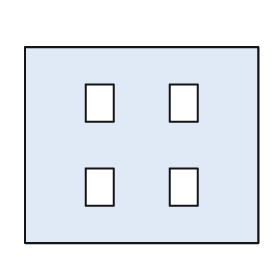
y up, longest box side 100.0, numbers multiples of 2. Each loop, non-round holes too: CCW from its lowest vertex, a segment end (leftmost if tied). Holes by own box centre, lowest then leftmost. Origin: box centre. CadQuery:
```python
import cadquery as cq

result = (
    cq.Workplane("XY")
    .moveTo(-50.0, -42.0)
    .lineTo(50.0, -42.0)
    .lineTo(50.0, 42.0)
    .lineTo(-50.0, 42.0)
    .close()
    .moveTo(-24.0, -26.0)
    .lineTo(-12.0, -26.0)
    .lineTo(-12.0, -10.0)
    .lineTo(-24.0, -10.0)
    .close()
    .moveTo(12.0, -26.0)
    .lineTo(24.0, -26.0)
    .lineTo(24.0, -10.0)
    .lineTo(12.0, -10.0)
    .close()
    .moveTo(-24.0, 10.0)
    .lineTo(-12.0, 10.0)
    .lineTo(-12.0, 26.0)
    .lineTo(-24.0, 26.0)
    .close()
    .moveTo(12.0, 10.0)
    .lineTo(24.0, 10.0)
    .lineTo(24.0, 26.0)
    .lineTo(12.0, 26.0)
    .close()
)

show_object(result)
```